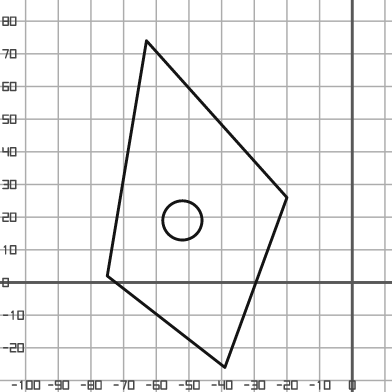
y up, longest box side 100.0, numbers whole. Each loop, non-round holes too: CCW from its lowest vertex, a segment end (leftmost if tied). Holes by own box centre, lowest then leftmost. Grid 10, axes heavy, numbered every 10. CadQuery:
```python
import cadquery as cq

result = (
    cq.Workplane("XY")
    .moveTo(-39.0, -26.0)
    .lineTo(-20.0, 26.0)
    .lineTo(-63.0, 74.0)
    .lineTo(-75.0, 2.0)
    .close()
    .moveTo(-52.0, 19.0)
    .circle(6.0)
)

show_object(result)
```